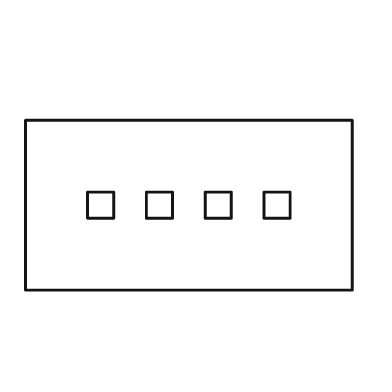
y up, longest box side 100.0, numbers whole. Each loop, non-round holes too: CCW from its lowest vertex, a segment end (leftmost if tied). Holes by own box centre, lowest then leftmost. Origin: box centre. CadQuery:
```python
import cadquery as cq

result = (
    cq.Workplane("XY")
    .moveTo(-50.0, -26.0)
    .lineTo(50.0, -26.0)
    .lineTo(50.0, 26.0)
    .lineTo(-50.0, 26.0)
    .close()
    .moveTo(-31.0, -4.0)
    .lineTo(-23.0, -4.0)
    .lineTo(-23.0, 4.0)
    .lineTo(-31.0, 4.0)
    .close()
    .moveTo(-13.0, -4.0)
    .lineTo(-5.0, -4.0)
    .lineTo(-5.0, 4.0)
    .lineTo(-13.0, 4.0)
    .close()
    .moveTo(5.0, -4.0)
    .lineTo(13.0, -4.0)
    .lineTo(13.0, 4.0)
    .lineTo(5.0, 4.0)
    .close()
    .moveTo(23.0, -4.0)
    .lineTo(31.0, -4.0)
    .lineTo(31.0, 4.0)
    .lineTo(23.0, 4.0)
    .close()
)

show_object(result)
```